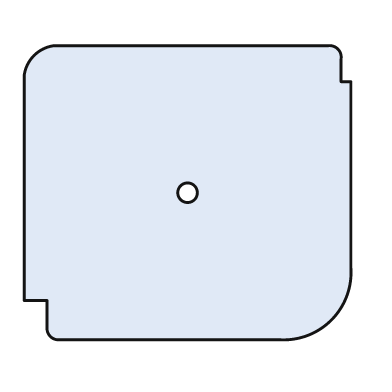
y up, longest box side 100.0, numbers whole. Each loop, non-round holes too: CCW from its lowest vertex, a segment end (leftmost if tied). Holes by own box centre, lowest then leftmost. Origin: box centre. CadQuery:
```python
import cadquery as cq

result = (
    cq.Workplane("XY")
    .moveTo(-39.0, -45.0)
    .lineTo(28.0, -45.0)
    .threePointArc((44.0, -39.0), (50.0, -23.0))
    .lineTo(50.0, 34.0)
    .lineTo(47.0, 34.0)
    .lineTo(47.0, 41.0)
    .threePointArc((46.0, 44.0), (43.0, 45.0))
    .lineTo(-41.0, 45.0)
    .threePointArc((-47.0, 42.0), (-50.0, 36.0))
    .lineTo(-50.0, -33.0)
    .lineTo(-43.0, -33.0)
    .lineTo(-43.0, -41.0)
    .threePointArc((-42.0, -44.0), (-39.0, -45.0))
    .close()
    .moveTo(0.0, 0.0)
    .circle(3.0)
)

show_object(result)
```